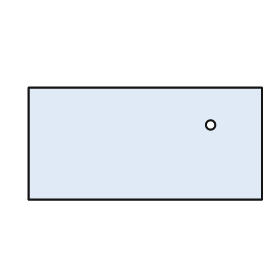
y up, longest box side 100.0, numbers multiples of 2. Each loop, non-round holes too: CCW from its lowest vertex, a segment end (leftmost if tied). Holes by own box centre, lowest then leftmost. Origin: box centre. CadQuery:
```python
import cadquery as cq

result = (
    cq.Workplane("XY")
    .moveTo(-50.0, -24.0)
    .lineTo(50.0, -24.0)
    .lineTo(50.0, 24.0)
    .lineTo(-50.0, 24.0)
    .close()
    .moveTo(28.0, 8.0)
    .circle(2.0)
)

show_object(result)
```